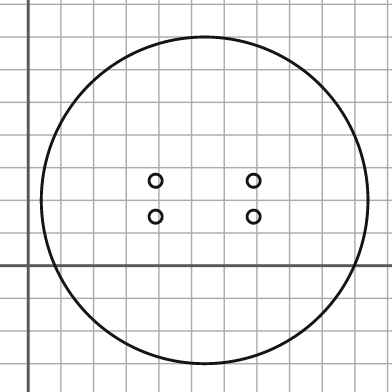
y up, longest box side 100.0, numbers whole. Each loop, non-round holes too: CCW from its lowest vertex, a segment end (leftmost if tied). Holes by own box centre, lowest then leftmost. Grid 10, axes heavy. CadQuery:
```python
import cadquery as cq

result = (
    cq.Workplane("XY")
    .moveTo(54.0, 20.0)
    .circle(50.0)
    .moveTo(39.0, 15.0)
    .circle(2.0)
    .moveTo(69.0, 15.0)
    .circle(2.0)
    .moveTo(39.0, 26.0)
    .circle(2.0)
    .moveTo(69.0, 26.0)
    .circle(2.0)
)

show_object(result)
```